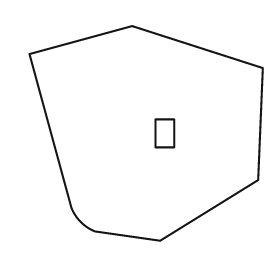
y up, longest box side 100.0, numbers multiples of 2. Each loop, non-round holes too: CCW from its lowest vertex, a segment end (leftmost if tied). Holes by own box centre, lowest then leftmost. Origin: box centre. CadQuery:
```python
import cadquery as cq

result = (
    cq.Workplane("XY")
    .moveTo(6.0, -46.0)
    .lineTo(48.0, -20.0)
    .lineTo(50.0, 28.0)
    .lineTo(-6.0, 46.0)
    .lineTo(-50.0, 34.0)
    .lineTo(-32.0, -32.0)
    .threePointArc((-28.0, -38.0), (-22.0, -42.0))
    .close()
    .moveTo(4.0, -6.0)
    .lineTo(12.0, -6.0)
    .lineTo(12.0, 6.0)
    .lineTo(4.0, 6.0)
    .close()
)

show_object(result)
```